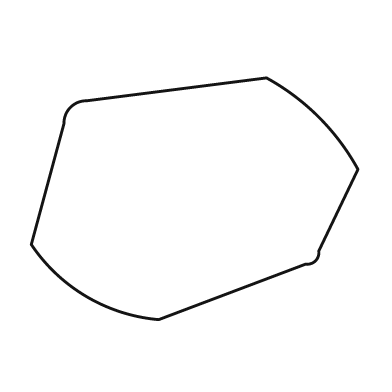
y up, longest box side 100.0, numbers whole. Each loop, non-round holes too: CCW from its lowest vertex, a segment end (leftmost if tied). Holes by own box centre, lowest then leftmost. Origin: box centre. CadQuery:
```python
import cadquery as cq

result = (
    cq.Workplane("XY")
    .moveTo(-11.0, -37.0)
    .lineTo(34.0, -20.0)
    .threePointArc((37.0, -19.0), (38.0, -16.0))
    .lineTo(50.0, 9.0)
    .threePointArc((38.0, 25.0), (22.0, 37.0))
    .lineTo(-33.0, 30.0)
    .threePointArc((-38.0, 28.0), (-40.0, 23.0))
    .lineTo(-50.0, -14.0)
    .threePointArc((-33.0, -30.0), (-11.0, -37.0))
    .close()
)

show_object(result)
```